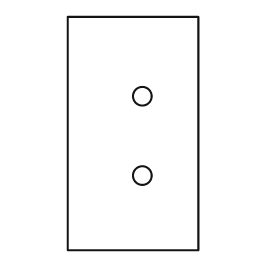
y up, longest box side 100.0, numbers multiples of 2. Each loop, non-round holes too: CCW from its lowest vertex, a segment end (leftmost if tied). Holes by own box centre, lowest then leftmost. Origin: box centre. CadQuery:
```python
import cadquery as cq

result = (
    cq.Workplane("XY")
    .moveTo(-28.0, -50.0)
    .lineTo(28.0, -50.0)
    .lineTo(28.0, 50.0)
    .lineTo(-28.0, 50.0)
    .close()
    .moveTo(4.0, -18.0)
    .circle(4.0)
    .moveTo(4.0, 16.0)
    .circle(4.0)
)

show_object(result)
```